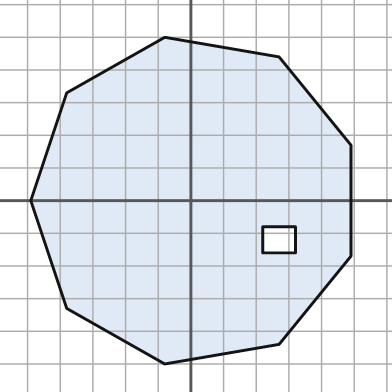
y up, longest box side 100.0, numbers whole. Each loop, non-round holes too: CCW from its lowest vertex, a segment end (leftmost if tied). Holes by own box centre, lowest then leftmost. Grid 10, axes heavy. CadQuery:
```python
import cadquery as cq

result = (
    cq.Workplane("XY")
    .moveTo(-8.0, -50.0)
    .lineTo(27.0, -44.0)
    .lineTo(49.0, -17.0)
    .lineTo(49.0, 17.0)
    .lineTo(27.0, 44.0)
    .lineTo(-8.0, 50.0)
    .lineTo(-38.0, 33.0)
    .lineTo(-49.0, 0.0)
    .lineTo(-38.0, -33.0)
    .close()
    .moveTo(22.0, -16.0)
    .lineTo(32.0, -16.0)
    .lineTo(32.0, -8.0)
    .lineTo(22.0, -8.0)
    .close()
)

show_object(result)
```